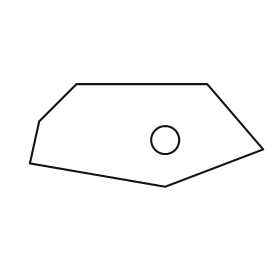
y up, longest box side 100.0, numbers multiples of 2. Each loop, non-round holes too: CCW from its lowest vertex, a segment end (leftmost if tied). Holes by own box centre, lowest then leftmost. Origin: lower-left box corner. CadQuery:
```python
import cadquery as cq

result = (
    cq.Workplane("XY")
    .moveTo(58.0, 0.0)
    .lineTo(100.0, 16.0)
    .lineTo(76.0, 44.0)
    .lineTo(20.0, 44.0)
    .lineTo(4.0, 28.0)
    .lineTo(0.0, 10.0)
    .close()
    .moveTo(58.0, 20.0)
    .circle(6.0)
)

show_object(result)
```